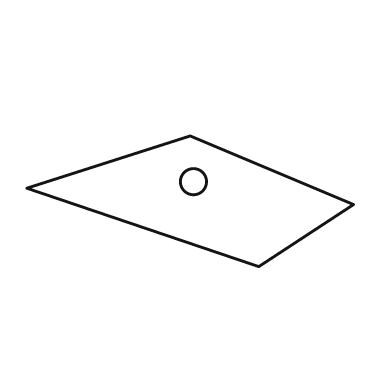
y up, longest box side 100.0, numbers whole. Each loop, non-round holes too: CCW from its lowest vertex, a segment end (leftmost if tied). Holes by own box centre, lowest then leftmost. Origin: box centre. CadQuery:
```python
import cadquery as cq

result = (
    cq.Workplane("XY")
    .moveTo(21.0, -20.0)
    .lineTo(50.0, -1.0)
    .lineTo(0.0, 20.0)
    .lineTo(-50.0, 4.0)
    .close()
    .moveTo(1.0, 6.0)
    .circle(4.0)
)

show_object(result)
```